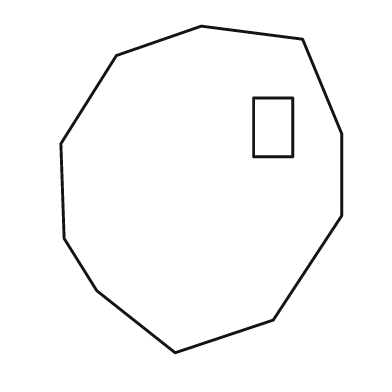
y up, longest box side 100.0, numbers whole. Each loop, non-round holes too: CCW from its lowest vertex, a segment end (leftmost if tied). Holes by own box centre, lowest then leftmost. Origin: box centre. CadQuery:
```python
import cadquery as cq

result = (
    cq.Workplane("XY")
    .moveTo(-8.0, -50.0)
    .lineTo(22.0, -40.0)
    .lineTo(43.0, -8.0)
    .lineTo(43.0, 17.0)
    .lineTo(31.0, 46.0)
    .lineTo(0.0, 50.0)
    .lineTo(-26.0, 41.0)
    .lineTo(-43.0, 14.0)
    .lineTo(-42.0, -15.0)
    .lineTo(-32.0, -31.0)
    .close()
    .moveTo(16.0, 10.0)
    .lineTo(28.0, 10.0)
    .lineTo(28.0, 28.0)
    .lineTo(16.0, 28.0)
    .close()
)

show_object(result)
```